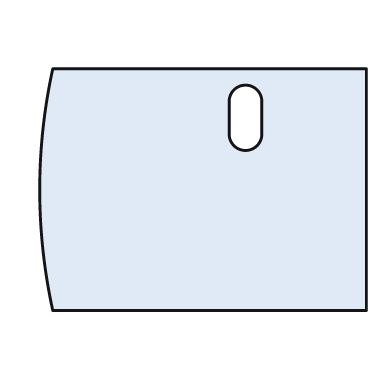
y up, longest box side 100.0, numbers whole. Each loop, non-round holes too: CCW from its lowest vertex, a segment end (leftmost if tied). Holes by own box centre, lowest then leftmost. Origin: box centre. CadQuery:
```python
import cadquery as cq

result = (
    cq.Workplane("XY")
    .moveTo(-46.0, -37.0)
    .lineTo(50.0, -37.0)
    .lineTo(50.0, 37.0)
    .lineTo(-46.0, 37.0)
    .threePointArc((-50.0, 0.0), (-46.0, -37.0))
    .close()
    .moveTo(8.0, 17.0)
    .threePointArc((13.0, 12.0), (18.0, 17.0))
    .lineTo(18.0, 27.0)
    .threePointArc((13.0, 32.0), (8.0, 27.0))
    .close()
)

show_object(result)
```